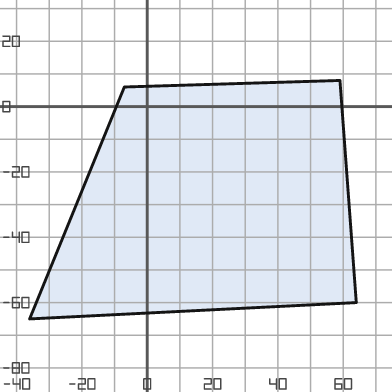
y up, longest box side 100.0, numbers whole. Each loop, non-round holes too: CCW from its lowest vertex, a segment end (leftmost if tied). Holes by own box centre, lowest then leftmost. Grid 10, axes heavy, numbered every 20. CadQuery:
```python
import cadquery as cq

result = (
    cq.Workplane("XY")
    .moveTo(-36.0, -65.0)
    .lineTo(64.0, -60.0)
    .lineTo(59.0, 8.0)
    .lineTo(-7.0, 6.0)
    .close()
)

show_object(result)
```